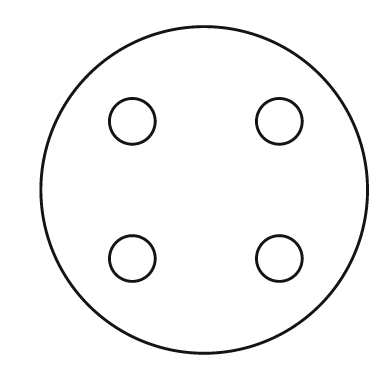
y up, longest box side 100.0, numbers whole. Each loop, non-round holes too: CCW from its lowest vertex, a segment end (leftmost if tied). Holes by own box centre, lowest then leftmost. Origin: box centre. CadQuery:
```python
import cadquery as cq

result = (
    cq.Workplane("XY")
    .moveTo(0.0, 0.0)
    .circle(50.0)
    .moveTo(-22.0, -21.0)
    .circle(7.0)
    .moveTo(23.0, -21.0)
    .circle(7.0)
    .moveTo(-22.0, 21.0)
    .circle(7.0)
    .moveTo(23.0, 21.0)
    .circle(7.0)
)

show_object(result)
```